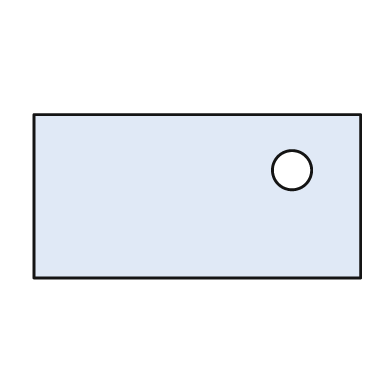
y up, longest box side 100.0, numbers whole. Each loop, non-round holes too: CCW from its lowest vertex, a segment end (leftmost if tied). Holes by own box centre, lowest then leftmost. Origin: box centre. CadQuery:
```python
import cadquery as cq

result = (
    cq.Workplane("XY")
    .moveTo(-50.0, -25.0)
    .lineTo(50.0, -25.0)
    .lineTo(50.0, 25.0)
    .lineTo(-50.0, 25.0)
    .close()
    .moveTo(29.0, 8.0)
    .circle(6.0)
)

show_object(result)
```